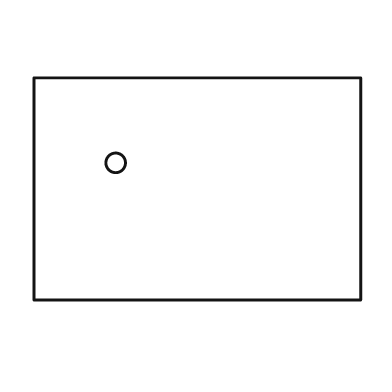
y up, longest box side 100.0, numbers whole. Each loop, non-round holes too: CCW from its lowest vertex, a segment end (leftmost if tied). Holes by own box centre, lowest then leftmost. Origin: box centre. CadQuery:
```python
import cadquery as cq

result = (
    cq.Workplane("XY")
    .moveTo(-50.0, -34.0)
    .lineTo(50.0, -34.0)
    .lineTo(50.0, 34.0)
    .lineTo(-50.0, 34.0)
    .close()
    .moveTo(-25.0, 8.0)
    .circle(3.0)
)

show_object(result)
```